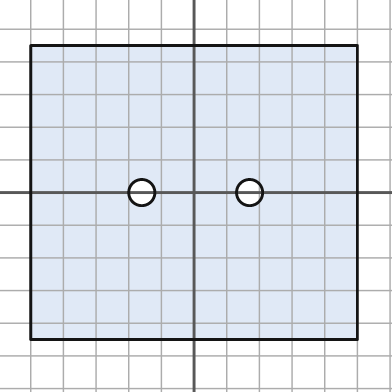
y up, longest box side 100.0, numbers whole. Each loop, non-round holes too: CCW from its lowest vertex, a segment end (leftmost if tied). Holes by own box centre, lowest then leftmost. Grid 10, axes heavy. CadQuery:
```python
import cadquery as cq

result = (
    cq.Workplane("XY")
    .moveTo(-50.0, -45.0)
    .lineTo(50.0, -45.0)
    .lineTo(50.0, 45.0)
    .lineTo(-50.0, 45.0)
    .close()
    .moveTo(-16.0, 0.0)
    .circle(4.0)
    .moveTo(17.0, 0.0)
    .circle(4.0)
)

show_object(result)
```